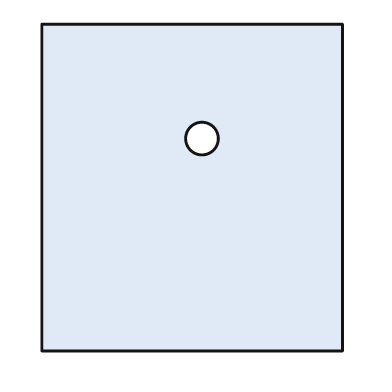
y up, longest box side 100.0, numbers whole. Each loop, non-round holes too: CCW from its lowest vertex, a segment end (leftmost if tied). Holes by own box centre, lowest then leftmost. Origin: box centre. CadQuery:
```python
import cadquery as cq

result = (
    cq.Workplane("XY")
    .moveTo(-46.0, -50.0)
    .lineTo(46.0, -50.0)
    .lineTo(46.0, 50.0)
    .lineTo(-46.0, 50.0)
    .close()
    .moveTo(3.0, 15.0)
    .circle(5.0)
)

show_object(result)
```